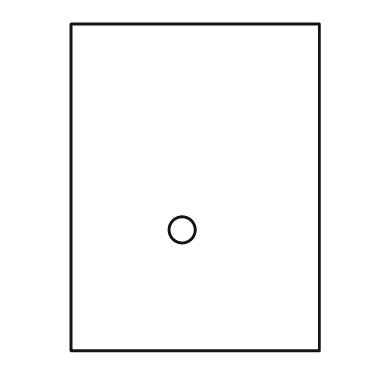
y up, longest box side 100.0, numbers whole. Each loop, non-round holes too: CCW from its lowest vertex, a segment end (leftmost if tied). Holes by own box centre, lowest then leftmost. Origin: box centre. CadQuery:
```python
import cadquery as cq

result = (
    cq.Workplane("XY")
    .moveTo(-38.0, -50.0)
    .lineTo(38.0, -50.0)
    .lineTo(38.0, 50.0)
    .lineTo(-38.0, 50.0)
    .close()
    .moveTo(-4.0, -13.0)
    .circle(4.0)
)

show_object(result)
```